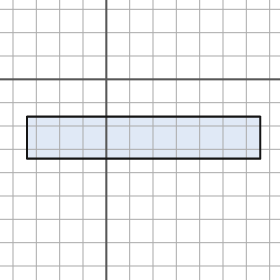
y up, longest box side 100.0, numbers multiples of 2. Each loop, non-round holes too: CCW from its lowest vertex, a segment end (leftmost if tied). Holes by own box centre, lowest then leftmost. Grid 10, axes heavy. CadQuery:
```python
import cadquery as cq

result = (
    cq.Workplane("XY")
    .moveTo(-34.0, -34.0)
    .lineTo(66.0, -34.0)
    .lineTo(66.0, -16.0)
    .lineTo(-34.0, -16.0)
    .close()
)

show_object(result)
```